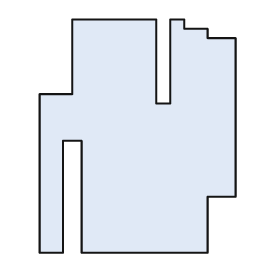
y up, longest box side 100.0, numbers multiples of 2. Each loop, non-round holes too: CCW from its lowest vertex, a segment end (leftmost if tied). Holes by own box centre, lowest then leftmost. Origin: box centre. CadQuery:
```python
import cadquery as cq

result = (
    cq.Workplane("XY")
    .moveTo(-42.0, -50.0)
    .lineTo(-32.0, -50.0)
    .lineTo(-32.0, -2.0)
    .lineTo(-24.0, -2.0)
    .lineTo(-24.0, -50.0)
    .lineTo(30.0, -50.0)
    .lineTo(30.0, -26.0)
    .lineTo(42.0, -26.0)
    .lineTo(42.0, 42.0)
    .lineTo(30.0, 42.0)
    .lineTo(30.0, 46.0)
    .lineTo(20.0, 46.0)
    .lineTo(20.0, 50.0)
    .lineTo(14.0, 50.0)
    .lineTo(14.0, 14.0)
    .lineTo(8.0, 14.0)
    .lineTo(8.0, 50.0)
    .lineTo(-28.0, 50.0)
    .lineTo(-28.0, 18.0)
    .lineTo(-42.0, 18.0)
    .close()
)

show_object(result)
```